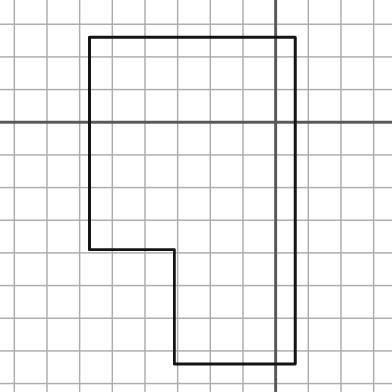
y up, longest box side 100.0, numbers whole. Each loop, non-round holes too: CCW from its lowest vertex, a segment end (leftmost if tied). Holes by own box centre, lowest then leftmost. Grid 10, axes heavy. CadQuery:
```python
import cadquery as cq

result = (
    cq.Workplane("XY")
    .moveTo(-31.0, -74.0)
    .lineTo(6.0, -74.0)
    .lineTo(6.0, 26.0)
    .lineTo(-57.0, 26.0)
    .lineTo(-57.0, -39.0)
    .lineTo(-31.0, -39.0)
    .close()
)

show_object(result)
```